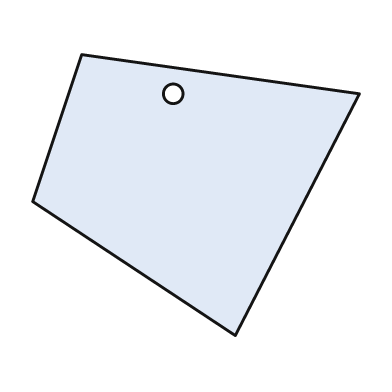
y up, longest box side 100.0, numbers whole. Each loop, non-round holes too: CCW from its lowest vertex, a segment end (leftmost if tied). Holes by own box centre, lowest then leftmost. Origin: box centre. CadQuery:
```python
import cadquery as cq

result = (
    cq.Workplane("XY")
    .moveTo(12.0, -43.0)
    .lineTo(50.0, 31.0)
    .lineTo(-35.0, 43.0)
    .lineTo(-50.0, -2.0)
    .close()
    .moveTo(-7.0, 31.0)
    .circle(3.0)
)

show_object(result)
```